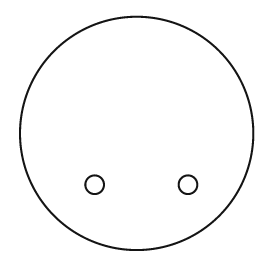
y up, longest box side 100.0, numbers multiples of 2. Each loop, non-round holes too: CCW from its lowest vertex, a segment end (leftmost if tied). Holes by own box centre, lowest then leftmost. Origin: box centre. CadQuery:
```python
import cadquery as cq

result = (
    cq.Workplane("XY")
    .moveTo(0.0, 0.0)
    .circle(50.0)
    .moveTo(-18.0, -22.0)
    .circle(4.0)
    .moveTo(22.0, -22.0)
    .circle(4.0)
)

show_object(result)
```